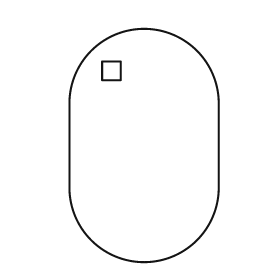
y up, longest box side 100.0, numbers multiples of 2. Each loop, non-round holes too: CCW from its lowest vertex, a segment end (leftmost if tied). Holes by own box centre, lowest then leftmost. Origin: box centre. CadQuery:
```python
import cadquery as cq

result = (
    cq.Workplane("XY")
    .moveTo(-32.0, -18.0)
    .threePointArc((0.0, -50.0), (32.0, -18.0))
    .lineTo(32.0, 18.0)
    .threePointArc((0.0, 50.0), (-32.0, 18.0))
    .close()
    .moveTo(-18.0, 28.0)
    .lineTo(-10.0, 28.0)
    .lineTo(-10.0, 36.0)
    .lineTo(-18.0, 36.0)
    .close()
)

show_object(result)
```